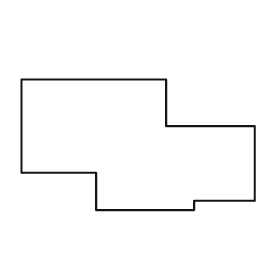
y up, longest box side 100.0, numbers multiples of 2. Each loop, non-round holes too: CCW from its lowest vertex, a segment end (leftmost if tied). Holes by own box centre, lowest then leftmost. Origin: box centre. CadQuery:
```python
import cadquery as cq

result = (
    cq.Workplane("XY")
    .moveTo(-18.0, -28.0)
    .lineTo(24.0, -28.0)
    .lineTo(24.0, -24.0)
    .lineTo(50.0, -24.0)
    .lineTo(50.0, 8.0)
    .lineTo(12.0, 8.0)
    .lineTo(12.0, 28.0)
    .lineTo(-50.0, 28.0)
    .lineTo(-50.0, -12.0)
    .lineTo(-18.0, -12.0)
    .close()
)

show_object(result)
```